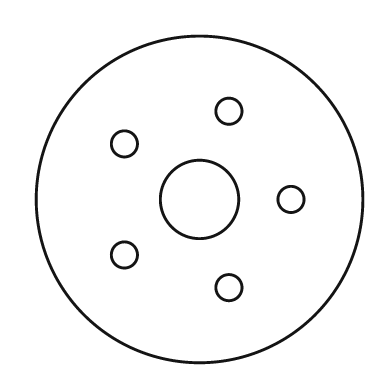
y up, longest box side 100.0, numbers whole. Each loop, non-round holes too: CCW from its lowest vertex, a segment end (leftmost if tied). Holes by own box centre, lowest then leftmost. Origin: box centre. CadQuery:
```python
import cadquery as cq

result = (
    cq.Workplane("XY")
    .moveTo(0.0, 0.0)
    .circle(50.0)
    .moveTo(9.0, -27.0)
    .circle(4.0)
    .moveTo(-23.0, -17.0)
    .circle(4.0)
    .moveTo(0.0, 0.0)
    .circle(12.0)
    .moveTo(28.0, 0.0)
    .circle(4.0)
    .moveTo(-23.0, 17.0)
    .circle(4.0)
    .moveTo(9.0, 27.0)
    .circle(4.0)
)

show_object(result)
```